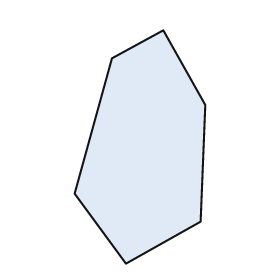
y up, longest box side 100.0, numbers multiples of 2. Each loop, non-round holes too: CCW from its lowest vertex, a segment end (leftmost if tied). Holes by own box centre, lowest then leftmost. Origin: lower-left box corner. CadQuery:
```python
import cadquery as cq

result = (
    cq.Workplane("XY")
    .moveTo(22.0, 0.0)
    .lineTo(54.0, 18.0)
    .lineTo(56.0, 68.0)
    .lineTo(38.0, 100.0)
    .lineTo(16.0, 88.0)
    .lineTo(0.0, 30.0)
    .close()
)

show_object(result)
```